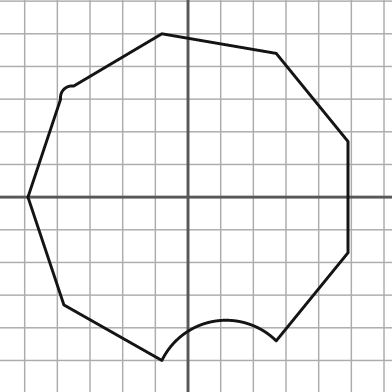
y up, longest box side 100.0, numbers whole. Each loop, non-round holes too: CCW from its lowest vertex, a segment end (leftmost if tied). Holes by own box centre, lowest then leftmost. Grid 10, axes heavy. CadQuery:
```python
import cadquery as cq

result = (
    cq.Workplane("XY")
    .moveTo(-8.0, -50.0)
    .threePointArc((8.0, -38.0), (27.0, -44.0))
    .lineTo(49.0, -17.0)
    .lineTo(49.0, 17.0)
    .lineTo(27.0, 44.0)
    .lineTo(-8.0, 50.0)
    .lineTo(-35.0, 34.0)
    .threePointArc((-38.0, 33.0), (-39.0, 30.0))
    .lineTo(-49.0, 0.0)
    .lineTo(-38.0, -33.0)
    .close()
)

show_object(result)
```